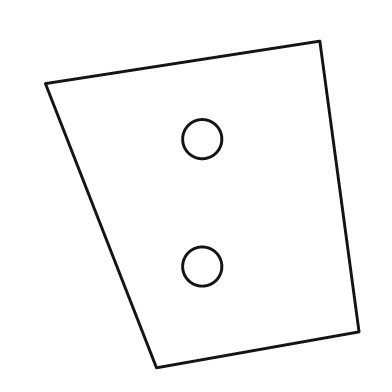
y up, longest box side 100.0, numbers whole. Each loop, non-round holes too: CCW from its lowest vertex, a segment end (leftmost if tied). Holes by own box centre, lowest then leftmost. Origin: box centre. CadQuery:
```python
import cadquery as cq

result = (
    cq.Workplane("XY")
    .moveTo(-14.0, -50.0)
    .lineTo(48.0, -39.0)
    .lineTo(36.0, 50.0)
    .lineTo(-48.0, 37.0)
    .close()
    .moveTo(0.0, -19.0)
    .circle(6.0)
    .moveTo(0.0, 20.0)
    .circle(6.0)
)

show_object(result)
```